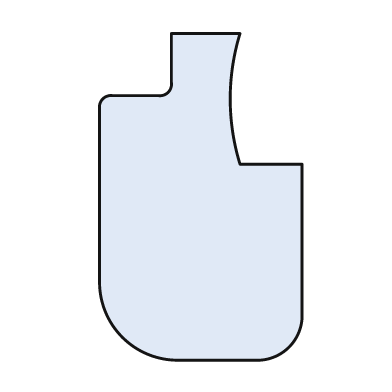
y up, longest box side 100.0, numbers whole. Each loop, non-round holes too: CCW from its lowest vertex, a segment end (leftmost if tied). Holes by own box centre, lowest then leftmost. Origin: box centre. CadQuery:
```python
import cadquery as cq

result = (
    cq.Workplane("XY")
    .moveTo(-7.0, -50.0)
    .lineTo(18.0, -50.0)
    .threePointArc((27.0, -46.0), (31.0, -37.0))
    .lineTo(31.0, 10.0)
    .lineTo(12.0, 10.0)
    .threePointArc((9.0, 30.0), (12.0, 50.0))
    .lineTo(-9.0, 50.0)
    .lineTo(-9.0, 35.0)
    .threePointArc((-10.0, 32.0), (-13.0, 31.0))
    .lineTo(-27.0, 31.0)
    .threePointArc((-30.0, 30.0), (-31.0, 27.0))
    .lineTo(-31.0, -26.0)
    .threePointArc((-24.0, -43.0), (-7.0, -50.0))
    .close()
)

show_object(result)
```